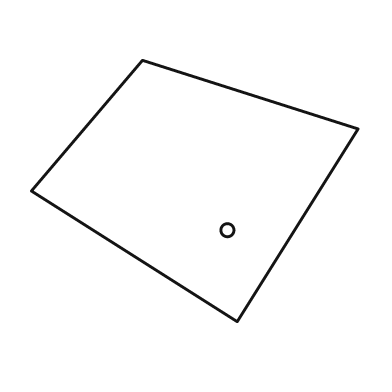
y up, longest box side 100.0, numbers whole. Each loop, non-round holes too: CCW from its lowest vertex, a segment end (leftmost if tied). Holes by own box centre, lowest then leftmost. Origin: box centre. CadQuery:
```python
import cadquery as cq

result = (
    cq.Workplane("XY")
    .moveTo(13.0, -40.0)
    .lineTo(50.0, 19.0)
    .lineTo(-16.0, 40.0)
    .lineTo(-50.0, 0.0)
    .close()
    .moveTo(10.0, -12.0)
    .circle(2.0)
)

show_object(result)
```